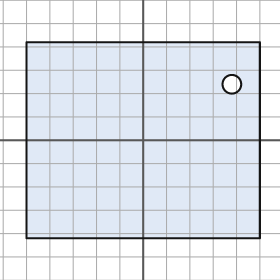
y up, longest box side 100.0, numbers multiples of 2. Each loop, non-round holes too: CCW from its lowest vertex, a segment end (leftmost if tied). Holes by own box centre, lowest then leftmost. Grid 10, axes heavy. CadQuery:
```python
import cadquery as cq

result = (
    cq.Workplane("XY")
    .moveTo(-50.0, -42.0)
    .lineTo(50.0, -42.0)
    .lineTo(50.0, 42.0)
    .lineTo(-50.0, 42.0)
    .close()
    .moveTo(38.0, 24.0)
    .circle(4.0)
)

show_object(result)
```